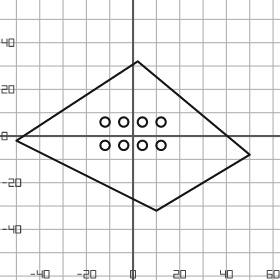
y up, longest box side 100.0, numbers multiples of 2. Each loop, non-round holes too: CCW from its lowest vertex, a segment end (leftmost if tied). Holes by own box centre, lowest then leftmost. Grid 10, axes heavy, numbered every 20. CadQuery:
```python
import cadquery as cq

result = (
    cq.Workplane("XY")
    .moveTo(10.0, -32.0)
    .lineTo(50.0, -8.0)
    .lineTo(2.0, 32.0)
    .lineTo(-50.0, -2.0)
    .close()
    .moveTo(-12.0, -4.0)
    .circle(2.0)
    .moveTo(-4.0, -4.0)
    .circle(2.0)
    .moveTo(4.0, -4.0)
    .circle(2.0)
    .moveTo(12.0, -4.0)
    .circle(2.0)
    .moveTo(-12.0, 6.0)
    .circle(2.0)
    .moveTo(-4.0, 6.0)
    .circle(2.0)
    .moveTo(4.0, 6.0)
    .circle(2.0)
    .moveTo(12.0, 6.0)
    .circle(2.0)
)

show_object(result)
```